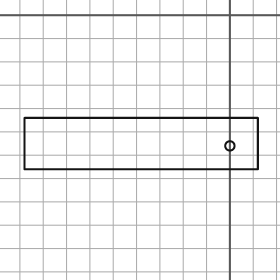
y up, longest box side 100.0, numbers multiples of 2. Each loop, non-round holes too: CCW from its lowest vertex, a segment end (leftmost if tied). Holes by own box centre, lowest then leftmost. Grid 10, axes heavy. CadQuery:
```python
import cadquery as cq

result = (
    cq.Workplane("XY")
    .moveTo(-88.0, -66.0)
    .lineTo(12.0, -66.0)
    .lineTo(12.0, -44.0)
    .lineTo(-88.0, -44.0)
    .close()
    .moveTo(0.0, -56.0)
    .circle(2.0)
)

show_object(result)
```